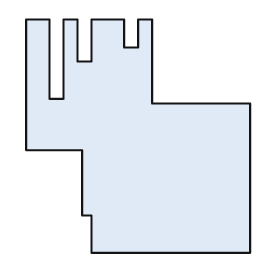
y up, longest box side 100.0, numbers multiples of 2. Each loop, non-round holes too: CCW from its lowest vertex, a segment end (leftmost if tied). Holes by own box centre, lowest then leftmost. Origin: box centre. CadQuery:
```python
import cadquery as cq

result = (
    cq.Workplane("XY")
    .moveTo(-20.0, -50.0)
    .lineTo(48.0, -50.0)
    .lineTo(48.0, 14.0)
    .lineTo(6.0, 14.0)
    .lineTo(6.0, 50.0)
    .lineTo(0.0, 50.0)
    .lineTo(0.0, 38.0)
    .lineTo(-6.0, 38.0)
    .lineTo(-6.0, 50.0)
    .lineTo(-20.0, 50.0)
    .lineTo(-20.0, 32.0)
    .lineTo(-26.0, 32.0)
    .lineTo(-26.0, 50.0)
    .lineTo(-32.0, 50.0)
    .lineTo(-32.0, 16.0)
    .lineTo(-38.0, 16.0)
    .lineTo(-38.0, 50.0)
    .lineTo(-48.0, 50.0)
    .lineTo(-48.0, -6.0)
    .lineTo(-24.0, -6.0)
    .lineTo(-24.0, -34.0)
    .lineTo(-20.0, -34.0)
    .close()
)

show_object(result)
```